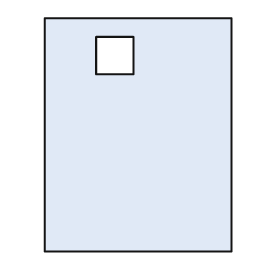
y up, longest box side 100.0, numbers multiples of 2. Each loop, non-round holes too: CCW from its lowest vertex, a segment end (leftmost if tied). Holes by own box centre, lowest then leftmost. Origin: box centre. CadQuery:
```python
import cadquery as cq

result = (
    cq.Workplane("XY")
    .moveTo(-40.0, -50.0)
    .lineTo(40.0, -50.0)
    .lineTo(40.0, 50.0)
    .lineTo(-40.0, 50.0)
    .close()
    .moveTo(-18.0, 26.0)
    .lineTo(-2.0, 26.0)
    .lineTo(-2.0, 42.0)
    .lineTo(-18.0, 42.0)
    .close()
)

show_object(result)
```